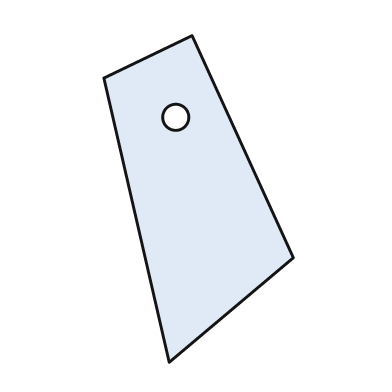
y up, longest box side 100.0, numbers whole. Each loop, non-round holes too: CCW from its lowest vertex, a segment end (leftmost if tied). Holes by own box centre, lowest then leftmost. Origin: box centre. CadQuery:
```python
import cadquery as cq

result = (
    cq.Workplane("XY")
    .moveTo(-9.0, -50.0)
    .lineTo(29.0, -18.0)
    .lineTo(-2.0, 50.0)
    .lineTo(-29.0, 37.0)
    .close()
    .moveTo(-7.0, 25.0)
    .circle(4.0)
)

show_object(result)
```